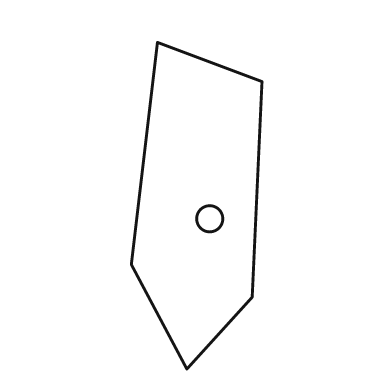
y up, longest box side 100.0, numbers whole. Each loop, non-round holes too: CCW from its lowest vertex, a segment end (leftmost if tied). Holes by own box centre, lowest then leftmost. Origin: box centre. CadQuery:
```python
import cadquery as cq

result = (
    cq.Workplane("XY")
    .moveTo(-3.0, -50.0)
    .lineTo(17.0, -28.0)
    .lineTo(20.0, 38.0)
    .lineTo(-12.0, 50.0)
    .lineTo(-20.0, -18.0)
    .close()
    .moveTo(4.0, -4.0)
    .circle(4.0)
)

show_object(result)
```